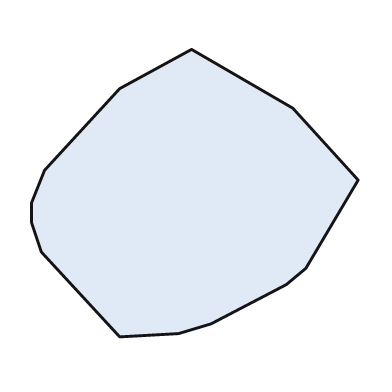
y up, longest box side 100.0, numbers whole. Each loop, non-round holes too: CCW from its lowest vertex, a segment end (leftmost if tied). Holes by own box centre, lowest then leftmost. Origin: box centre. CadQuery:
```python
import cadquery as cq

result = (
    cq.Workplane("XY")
    .moveTo(-23.0, -44.0)
    .lineTo(-5.0, -43.0)
    .lineTo(5.0, -40.0)
    .lineTo(28.0, -28.0)
    .lineTo(34.0, -23.0)
    .lineTo(50.0, 4.0)
    .lineTo(30.0, 26.0)
    .lineTo(-1.0, 44.0)
    .lineTo(-23.0, 32.0)
    .lineTo(-46.0, 7.0)
    .lineTo(-50.0, -3.0)
    .lineTo(-50.0, -9.0)
    .lineTo(-47.0, -18.0)
    .close()
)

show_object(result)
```